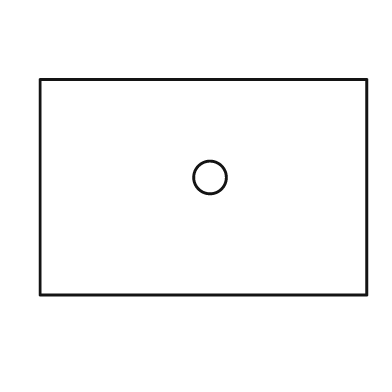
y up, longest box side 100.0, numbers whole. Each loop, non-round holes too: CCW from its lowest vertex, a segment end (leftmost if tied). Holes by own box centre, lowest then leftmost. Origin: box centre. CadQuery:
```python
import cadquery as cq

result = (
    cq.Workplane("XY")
    .moveTo(-50.0, -33.0)
    .lineTo(50.0, -33.0)
    .lineTo(50.0, 33.0)
    .lineTo(-50.0, 33.0)
    .close()
    .moveTo(2.0, 3.0)
    .circle(5.0)
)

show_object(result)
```